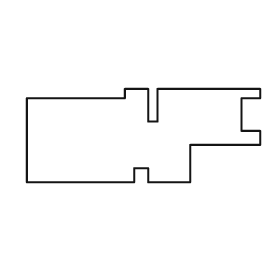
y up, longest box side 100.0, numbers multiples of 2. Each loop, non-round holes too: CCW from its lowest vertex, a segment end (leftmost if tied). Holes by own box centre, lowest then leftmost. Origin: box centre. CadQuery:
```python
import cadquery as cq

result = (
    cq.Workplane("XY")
    .moveTo(-50.0, -20.0)
    .lineTo(-4.0, -20.0)
    .lineTo(-4.0, -14.0)
    .lineTo(2.0, -14.0)
    .lineTo(2.0, -20.0)
    .lineTo(20.0, -20.0)
    .lineTo(20.0, -4.0)
    .lineTo(50.0, -4.0)
    .lineTo(50.0, 2.0)
    .lineTo(42.0, 2.0)
    .lineTo(42.0, 16.0)
    .lineTo(50.0, 16.0)
    .lineTo(50.0, 20.0)
    .lineTo(6.0, 20.0)
    .lineTo(6.0, 6.0)
    .lineTo(2.0, 6.0)
    .lineTo(2.0, 20.0)
    .lineTo(-8.0, 20.0)
    .lineTo(-8.0, 16.0)
    .lineTo(-50.0, 16.0)
    .close()
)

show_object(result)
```